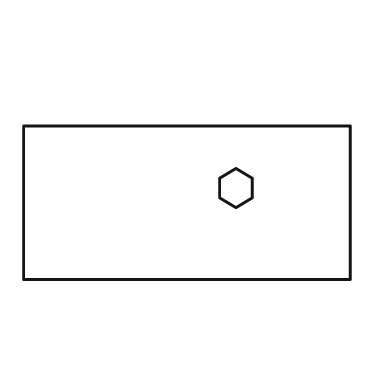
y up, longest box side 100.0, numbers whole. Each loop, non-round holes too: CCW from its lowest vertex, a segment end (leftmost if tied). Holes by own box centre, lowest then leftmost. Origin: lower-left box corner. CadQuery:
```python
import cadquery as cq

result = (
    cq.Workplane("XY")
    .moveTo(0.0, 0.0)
    .lineTo(100.0, 0.0)
    .lineTo(100.0, 47.0)
    .lineTo(0.0, 47.0)
    .close()
    .moveTo(65.0, 22.0)
    .lineTo(70.0, 25.0)
    .lineTo(70.0, 31.0)
    .lineTo(65.0, 34.0)
    .lineTo(60.0, 31.0)
    .lineTo(60.0, 25.0)
    .close()
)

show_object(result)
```